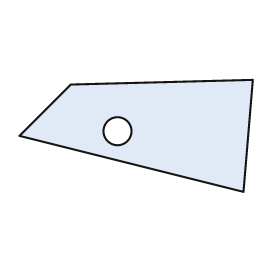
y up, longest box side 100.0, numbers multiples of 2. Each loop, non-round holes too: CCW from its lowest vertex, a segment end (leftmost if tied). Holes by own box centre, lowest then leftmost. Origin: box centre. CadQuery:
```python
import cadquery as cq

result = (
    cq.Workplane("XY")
    .moveTo(46.0, -24.0)
    .lineTo(50.0, 24.0)
    .lineTo(-28.0, 22.0)
    .lineTo(-50.0, 0.0)
    .close()
    .moveTo(-8.0, 2.0)
    .circle(6.0)
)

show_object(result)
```